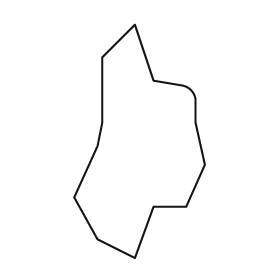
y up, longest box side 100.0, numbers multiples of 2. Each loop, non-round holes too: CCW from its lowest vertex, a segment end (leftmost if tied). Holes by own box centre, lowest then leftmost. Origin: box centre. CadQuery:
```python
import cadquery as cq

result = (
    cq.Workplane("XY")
    .moveTo(-2.0, -50.0)
    .lineTo(6.0, -28.0)
    .lineTo(20.0, -28.0)
    .lineTo(28.0, -10.0)
    .lineTo(24.0, 8.0)
    .lineTo(24.0, 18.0)
    .threePointArc((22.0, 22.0), (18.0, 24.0))
    .lineTo(6.0, 26.0)
    .lineTo(-2.0, 50.0)
    .lineTo(-16.0, 36.0)
    .lineTo(-16.0, 8.0)
    .lineTo(-18.0, -2.0)
    .lineTo(-28.0, -24.0)
    .lineTo(-18.0, -42.0)
    .close()
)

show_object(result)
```